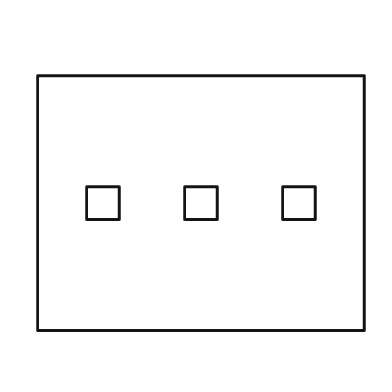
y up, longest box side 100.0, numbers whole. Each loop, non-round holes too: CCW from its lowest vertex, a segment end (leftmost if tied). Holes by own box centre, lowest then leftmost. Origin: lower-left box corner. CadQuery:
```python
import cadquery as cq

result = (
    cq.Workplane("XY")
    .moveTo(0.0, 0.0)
    .lineTo(100.0, 0.0)
    .lineTo(100.0, 78.0)
    .lineTo(0.0, 78.0)
    .close()
    .moveTo(15.0, 34.0)
    .lineTo(25.0, 34.0)
    .lineTo(25.0, 44.0)
    .lineTo(15.0, 44.0)
    .close()
    .moveTo(45.0, 34.0)
    .lineTo(55.0, 34.0)
    .lineTo(55.0, 44.0)
    .lineTo(45.0, 44.0)
    .close()
    .moveTo(75.0, 34.0)
    .lineTo(85.0, 34.0)
    .lineTo(85.0, 44.0)
    .lineTo(75.0, 44.0)
    .close()
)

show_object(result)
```